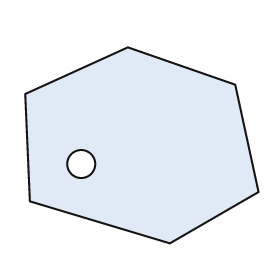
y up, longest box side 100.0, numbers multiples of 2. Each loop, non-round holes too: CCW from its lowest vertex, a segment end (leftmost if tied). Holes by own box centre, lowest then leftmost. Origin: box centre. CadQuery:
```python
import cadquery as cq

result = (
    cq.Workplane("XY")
    .moveTo(12.0, -42.0)
    .lineTo(50.0, -20.0)
    .lineTo(40.0, 26.0)
    .lineTo(-6.0, 42.0)
    .lineTo(-50.0, 22.0)
    .lineTo(-48.0, -24.0)
    .close()
    .moveTo(-26.0, -8.0)
    .circle(6.0)
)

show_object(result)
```